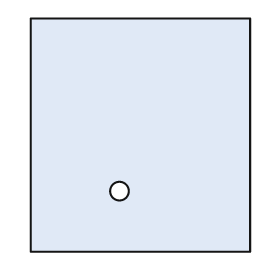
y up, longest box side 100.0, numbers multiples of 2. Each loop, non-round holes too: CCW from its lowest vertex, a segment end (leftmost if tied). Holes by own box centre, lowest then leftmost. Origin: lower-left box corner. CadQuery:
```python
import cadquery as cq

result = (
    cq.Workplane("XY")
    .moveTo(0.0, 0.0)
    .lineTo(94.0, 0.0)
    .lineTo(94.0, 100.0)
    .lineTo(0.0, 100.0)
    .close()
    .moveTo(38.0, 26.0)
    .circle(4.0)
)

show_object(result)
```